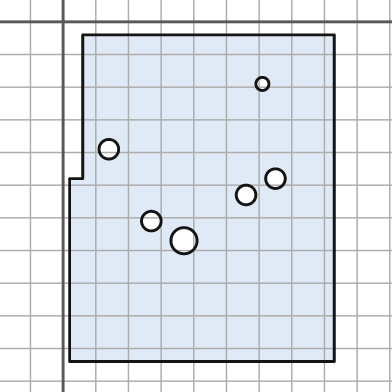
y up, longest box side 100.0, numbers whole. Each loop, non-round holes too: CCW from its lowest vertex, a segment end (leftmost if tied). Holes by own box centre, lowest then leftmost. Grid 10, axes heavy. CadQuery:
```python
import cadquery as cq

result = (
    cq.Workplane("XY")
    .moveTo(2.0, -104.0)
    .lineTo(83.0, -104.0)
    .lineTo(83.0, -4.0)
    .lineTo(6.0, -4.0)
    .lineTo(6.0, -48.0)
    .lineTo(2.0, -48.0)
    .close()
    .moveTo(37.0, -67.0)
    .circle(4.0)
    .moveTo(27.0, -61.0)
    .circle(3.0)
    .moveTo(56.0, -53.0)
    .circle(3.0)
    .moveTo(65.0, -48.0)
    .circle(3.0)
    .moveTo(14.0, -39.0)
    .circle(3.0)
    .moveTo(61.0, -19.0)
    .circle(2.0)
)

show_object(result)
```